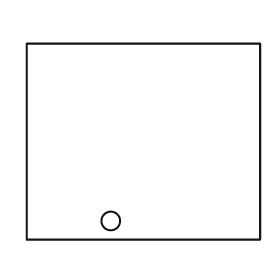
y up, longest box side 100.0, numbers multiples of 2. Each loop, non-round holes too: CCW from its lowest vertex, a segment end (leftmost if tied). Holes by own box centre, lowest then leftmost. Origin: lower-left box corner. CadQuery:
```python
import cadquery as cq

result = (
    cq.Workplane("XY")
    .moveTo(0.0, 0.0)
    .lineTo(100.0, 0.0)
    .lineTo(100.0, 84.0)
    .lineTo(0.0, 84.0)
    .close()
    .moveTo(36.0, 8.0)
    .circle(4.0)
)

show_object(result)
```